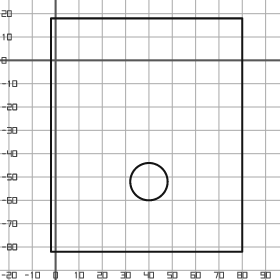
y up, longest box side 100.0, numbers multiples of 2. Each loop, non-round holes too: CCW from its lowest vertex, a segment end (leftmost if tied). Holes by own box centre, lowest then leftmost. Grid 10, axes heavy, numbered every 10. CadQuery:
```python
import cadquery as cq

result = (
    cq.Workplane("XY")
    .moveTo(-2.0, -82.0)
    .lineTo(80.0, -82.0)
    .lineTo(80.0, 18.0)
    .lineTo(-2.0, 18.0)
    .close()
    .moveTo(40.0, -52.0)
    .circle(8.0)
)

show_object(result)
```